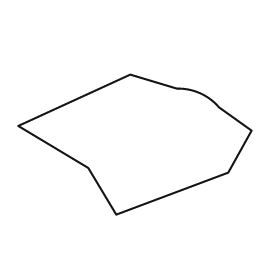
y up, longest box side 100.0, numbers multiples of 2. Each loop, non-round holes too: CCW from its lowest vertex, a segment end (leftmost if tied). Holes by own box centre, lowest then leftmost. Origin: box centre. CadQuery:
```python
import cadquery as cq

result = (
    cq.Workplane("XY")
    .moveTo(-8.0, -30.0)
    .lineTo(40.0, -12.0)
    .lineTo(50.0, 6.0)
    .lineTo(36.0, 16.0)
    .threePointArc((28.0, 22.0), (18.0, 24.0))
    .lineTo(-2.0, 30.0)
    .lineTo(-50.0, 8.0)
    .lineTo(-20.0, -10.0)
    .close()
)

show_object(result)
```